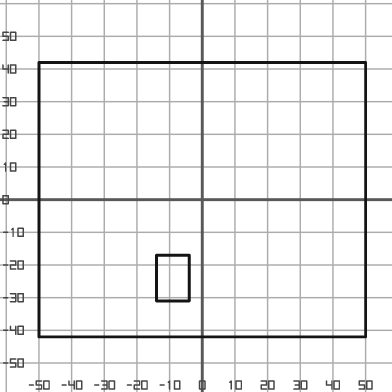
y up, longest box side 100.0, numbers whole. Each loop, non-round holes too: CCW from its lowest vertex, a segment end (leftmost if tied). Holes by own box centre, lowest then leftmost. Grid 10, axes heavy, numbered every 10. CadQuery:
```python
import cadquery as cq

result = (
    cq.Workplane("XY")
    .moveTo(-50.0, -42.0)
    .lineTo(50.0, -42.0)
    .lineTo(50.0, 42.0)
    .lineTo(-50.0, 42.0)
    .close()
    .moveTo(-14.0, -31.0)
    .lineTo(-4.0, -31.0)
    .lineTo(-4.0, -17.0)
    .lineTo(-14.0, -17.0)
    .close()
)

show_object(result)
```